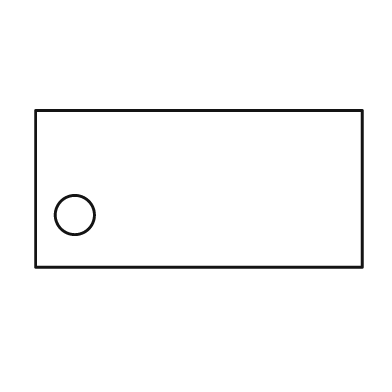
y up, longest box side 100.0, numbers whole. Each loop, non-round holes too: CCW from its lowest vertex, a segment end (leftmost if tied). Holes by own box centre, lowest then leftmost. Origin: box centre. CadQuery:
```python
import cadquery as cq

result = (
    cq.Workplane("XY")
    .moveTo(-50.0, -24.0)
    .lineTo(50.0, -24.0)
    .lineTo(50.0, 24.0)
    .lineTo(-50.0, 24.0)
    .close()
    .moveTo(-38.0, -8.0)
    .circle(6.0)
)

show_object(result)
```